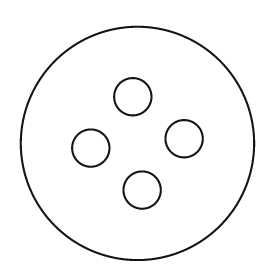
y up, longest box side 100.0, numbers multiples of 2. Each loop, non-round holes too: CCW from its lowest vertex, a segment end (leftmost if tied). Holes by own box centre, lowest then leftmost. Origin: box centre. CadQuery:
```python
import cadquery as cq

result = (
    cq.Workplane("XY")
    .moveTo(0.0, 0.0)
    .circle(50.0)
    .moveTo(2.0, -20.0)
    .circle(8.0)
    .moveTo(-20.0, -2.0)
    .circle(8.0)
    .moveTo(20.0, 2.0)
    .circle(8.0)
    .moveTo(-2.0, 20.0)
    .circle(8.0)
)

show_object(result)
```